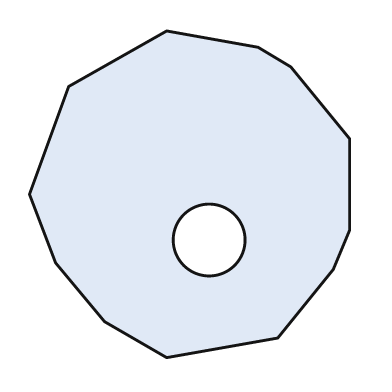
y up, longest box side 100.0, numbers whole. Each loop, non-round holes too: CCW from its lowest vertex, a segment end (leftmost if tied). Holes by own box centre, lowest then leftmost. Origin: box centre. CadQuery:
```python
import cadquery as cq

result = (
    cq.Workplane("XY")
    .moveTo(-7.0, -50.0)
    .lineTo(27.0, -44.0)
    .lineTo(44.0, -23.0)
    .lineTo(49.0, -11.0)
    .lineTo(49.0, 17.0)
    .lineTo(31.0, 39.0)
    .lineTo(21.0, 45.0)
    .lineTo(-7.0, 50.0)
    .lineTo(-37.0, 33.0)
    .lineTo(-49.0, 0.0)
    .lineTo(-41.0, -21.0)
    .lineTo(-26.0, -39.0)
    .close()
    .moveTo(6.0, -14.0)
    .circle(11.0)
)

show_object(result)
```